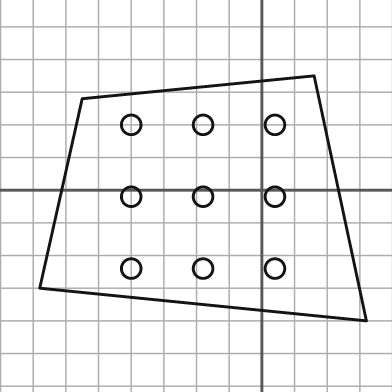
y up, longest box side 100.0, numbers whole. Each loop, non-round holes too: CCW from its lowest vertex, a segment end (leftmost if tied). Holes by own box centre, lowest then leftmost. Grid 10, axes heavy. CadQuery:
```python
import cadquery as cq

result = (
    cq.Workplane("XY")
    .moveTo(32.0, -40.0)
    .lineTo(16.0, 35.0)
    .lineTo(-55.0, 28.0)
    .lineTo(-68.0, -30.0)
    .close()
    .moveTo(-40.0, -24.0)
    .circle(3.0)
    .moveTo(-18.0, -24.0)
    .circle(3.0)
    .moveTo(4.0, -24.0)
    .circle(3.0)
    .moveTo(-40.0, -2.0)
    .circle(3.0)
    .moveTo(-18.0, -2.0)
    .circle(3.0)
    .moveTo(4.0, -2.0)
    .circle(3.0)
    .moveTo(-40.0, 20.0)
    .circle(3.0)
    .moveTo(-18.0, 20.0)
    .circle(3.0)
    .moveTo(4.0, 20.0)
    .circle(3.0)
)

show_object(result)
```